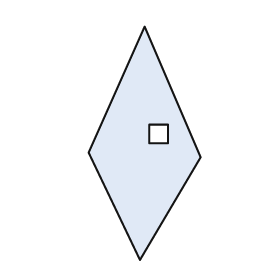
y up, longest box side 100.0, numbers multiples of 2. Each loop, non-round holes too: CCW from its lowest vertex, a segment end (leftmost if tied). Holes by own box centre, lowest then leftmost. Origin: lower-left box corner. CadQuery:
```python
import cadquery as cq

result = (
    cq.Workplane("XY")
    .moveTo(22.0, 0.0)
    .lineTo(48.0, 44.0)
    .lineTo(24.0, 100.0)
    .lineTo(0.0, 46.0)
    .close()
    .moveTo(26.0, 50.0)
    .lineTo(34.0, 50.0)
    .lineTo(34.0, 58.0)
    .lineTo(26.0, 58.0)
    .close()
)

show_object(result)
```